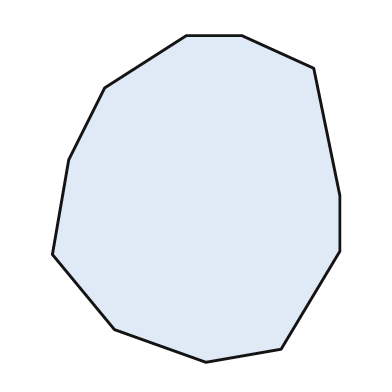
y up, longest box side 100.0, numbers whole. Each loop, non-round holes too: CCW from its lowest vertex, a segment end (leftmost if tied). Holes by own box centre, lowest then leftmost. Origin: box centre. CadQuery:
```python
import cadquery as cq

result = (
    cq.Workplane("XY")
    .moveTo(3.0, -50.0)
    .lineTo(26.0, -46.0)
    .lineTo(44.0, -16.0)
    .lineTo(44.0, 1.0)
    .lineTo(36.0, 40.0)
    .lineTo(14.0, 50.0)
    .lineTo(-3.0, 50.0)
    .lineTo(-28.0, 34.0)
    .lineTo(-39.0, 12.0)
    .lineTo(-44.0, -17.0)
    .lineTo(-25.0, -40.0)
    .close()
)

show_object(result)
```